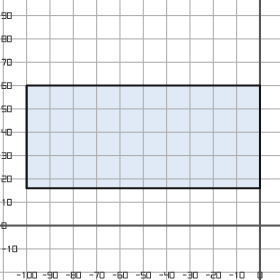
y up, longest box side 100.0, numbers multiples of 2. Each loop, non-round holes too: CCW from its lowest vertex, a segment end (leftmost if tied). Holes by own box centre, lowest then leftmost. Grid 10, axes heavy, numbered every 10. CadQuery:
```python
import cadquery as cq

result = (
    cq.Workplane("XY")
    .moveTo(-100.0, 16.0)
    .lineTo(0.0, 16.0)
    .lineTo(0.0, 60.0)
    .lineTo(-100.0, 60.0)
    .close()
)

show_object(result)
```